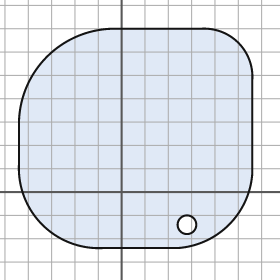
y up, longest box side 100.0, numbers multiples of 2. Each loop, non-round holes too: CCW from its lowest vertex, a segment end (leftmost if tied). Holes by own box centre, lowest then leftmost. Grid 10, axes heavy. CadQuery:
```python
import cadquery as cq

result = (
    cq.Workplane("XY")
    .moveTo(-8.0, -24.0)
    .lineTo(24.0, -24.0)
    .threePointArc((46.0, -14.0), (56.0, 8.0))
    .lineTo(56.0, 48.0)
    .threePointArc((50.0, 64.0), (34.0, 70.0))
    .lineTo(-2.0, 70.0)
    .threePointArc((-32.0, 58.0), (-44.0, 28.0))
    .lineTo(-44.0, 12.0)
    .threePointArc((-34.0, -14.0), (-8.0, -24.0))
    .close()
    .moveTo(28.0, -14.0)
    .circle(4.0)
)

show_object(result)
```